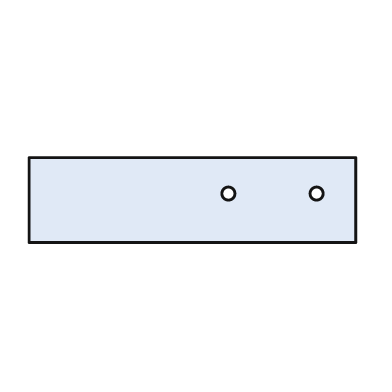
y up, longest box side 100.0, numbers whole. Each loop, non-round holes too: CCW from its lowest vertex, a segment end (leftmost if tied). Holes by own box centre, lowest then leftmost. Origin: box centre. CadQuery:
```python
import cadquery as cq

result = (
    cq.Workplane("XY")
    .moveTo(-50.0, -13.0)
    .lineTo(50.0, -13.0)
    .lineTo(50.0, 13.0)
    .lineTo(-50.0, 13.0)
    .close()
    .moveTo(11.0, 2.0)
    .circle(2.0)
    .moveTo(38.0, 2.0)
    .circle(2.0)
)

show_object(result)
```